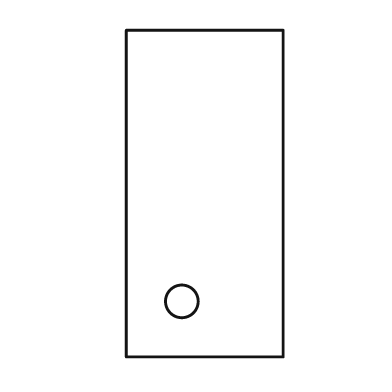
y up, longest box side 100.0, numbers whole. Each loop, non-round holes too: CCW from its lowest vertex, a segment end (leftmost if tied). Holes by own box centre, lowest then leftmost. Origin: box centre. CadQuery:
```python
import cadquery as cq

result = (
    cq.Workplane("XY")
    .moveTo(-24.0, -50.0)
    .lineTo(24.0, -50.0)
    .lineTo(24.0, 50.0)
    .lineTo(-24.0, 50.0)
    .close()
    .moveTo(-7.0, -33.0)
    .circle(5.0)
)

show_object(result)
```